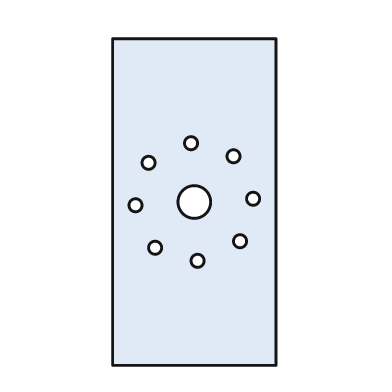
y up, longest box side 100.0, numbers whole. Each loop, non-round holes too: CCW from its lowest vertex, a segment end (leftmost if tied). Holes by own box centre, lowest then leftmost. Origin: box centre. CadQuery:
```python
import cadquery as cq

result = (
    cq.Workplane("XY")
    .moveTo(-25.0, -50.0)
    .lineTo(25.0, -50.0)
    .lineTo(25.0, 50.0)
    .lineTo(-25.0, 50.0)
    .close()
    .moveTo(1.0, -18.0)
    .circle(2.0)
    .moveTo(-12.0, -14.0)
    .circle(2.0)
    .moveTo(14.0, -12.0)
    .circle(2.0)
    .moveTo(-18.0, -1.0)
    .circle(2.0)
    .moveTo(0.0, 0.0)
    .circle(5.0)
    .moveTo(18.0, 1.0)
    .circle(2.0)
    .moveTo(-14.0, 12.0)
    .circle(2.0)
    .moveTo(12.0, 14.0)
    .circle(2.0)
    .moveTo(-1.0, 18.0)
    .circle(2.0)
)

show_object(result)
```